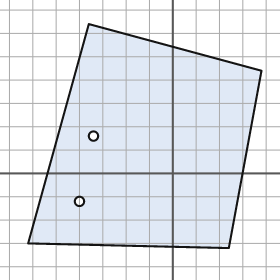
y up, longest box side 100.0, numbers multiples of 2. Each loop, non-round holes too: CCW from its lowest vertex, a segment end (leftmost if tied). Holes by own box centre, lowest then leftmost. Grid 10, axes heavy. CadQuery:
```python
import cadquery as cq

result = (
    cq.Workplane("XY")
    .moveTo(24.0, -32.0)
    .lineTo(38.0, 44.0)
    .lineTo(-36.0, 64.0)
    .lineTo(-62.0, -30.0)
    .close()
    .moveTo(-40.0, -12.0)
    .circle(2.0)
    .moveTo(-34.0, 16.0)
    .circle(2.0)
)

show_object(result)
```